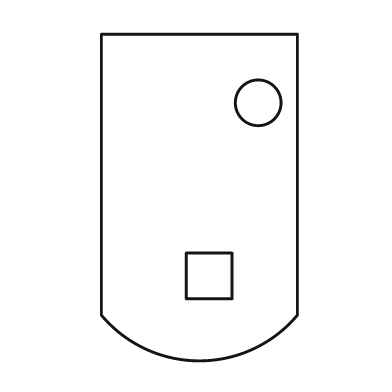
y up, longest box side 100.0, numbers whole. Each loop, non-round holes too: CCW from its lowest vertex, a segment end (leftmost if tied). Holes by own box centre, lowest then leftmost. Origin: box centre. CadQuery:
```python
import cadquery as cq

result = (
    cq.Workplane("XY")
    .moveTo(-30.0, -36.0)
    .threePointArc((0.0, -50.0), (30.0, -36.0))
    .lineTo(30.0, 50.0)
    .lineTo(-30.0, 50.0)
    .close()
    .moveTo(-4.0, -31.0)
    .lineTo(10.0, -31.0)
    .lineTo(10.0, -17.0)
    .lineTo(-4.0, -17.0)
    .close()
    .moveTo(18.0, 29.0)
    .circle(7.0)
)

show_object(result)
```